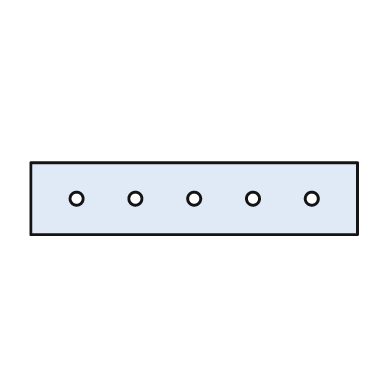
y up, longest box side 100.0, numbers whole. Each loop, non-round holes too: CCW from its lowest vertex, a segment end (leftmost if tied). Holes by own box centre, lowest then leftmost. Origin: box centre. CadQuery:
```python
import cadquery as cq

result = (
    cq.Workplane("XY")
    .moveTo(-50.0, -11.0)
    .lineTo(50.0, -11.0)
    .lineTo(50.0, 11.0)
    .lineTo(-50.0, 11.0)
    .close()
    .moveTo(-36.0, 0.0)
    .circle(2.0)
    .moveTo(-18.0, 0.0)
    .circle(2.0)
    .moveTo(0.0, 0.0)
    .circle(2.0)
    .moveTo(18.0, 0.0)
    .circle(2.0)
    .moveTo(36.0, 0.0)
    .circle(2.0)
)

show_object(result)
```